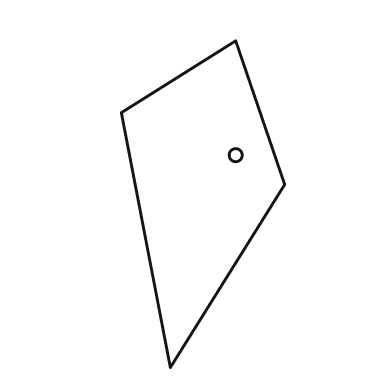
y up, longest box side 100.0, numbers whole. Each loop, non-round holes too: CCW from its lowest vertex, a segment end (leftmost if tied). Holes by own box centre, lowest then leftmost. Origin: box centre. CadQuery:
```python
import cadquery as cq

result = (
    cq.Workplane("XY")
    .moveTo(-10.0, -50.0)
    .lineTo(25.0, 6.0)
    .lineTo(10.0, 50.0)
    .lineTo(-25.0, 28.0)
    .close()
    .moveTo(10.0, 15.0)
    .circle(2.0)
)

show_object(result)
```